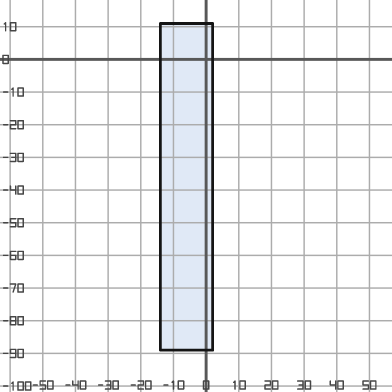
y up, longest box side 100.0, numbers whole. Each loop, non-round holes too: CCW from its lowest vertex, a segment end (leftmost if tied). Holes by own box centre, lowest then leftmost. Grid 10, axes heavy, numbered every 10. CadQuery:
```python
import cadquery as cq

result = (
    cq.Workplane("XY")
    .moveTo(-14.0, -89.0)
    .lineTo(2.0, -89.0)
    .lineTo(2.0, 11.0)
    .lineTo(-14.0, 11.0)
    .close()
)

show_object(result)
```